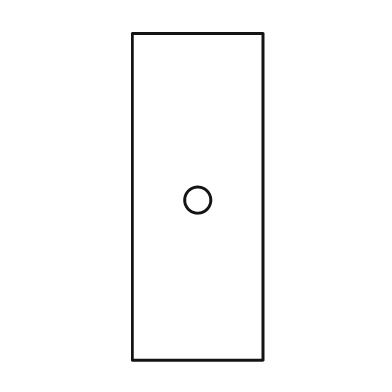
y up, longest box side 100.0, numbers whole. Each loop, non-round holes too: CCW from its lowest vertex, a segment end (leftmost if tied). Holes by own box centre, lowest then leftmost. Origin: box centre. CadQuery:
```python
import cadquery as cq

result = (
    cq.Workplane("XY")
    .moveTo(-20.0, -50.0)
    .lineTo(20.0, -50.0)
    .lineTo(20.0, 50.0)
    .lineTo(-20.0, 50.0)
    .close()
    .moveTo(0.0, -1.0)
    .circle(4.0)
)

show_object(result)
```